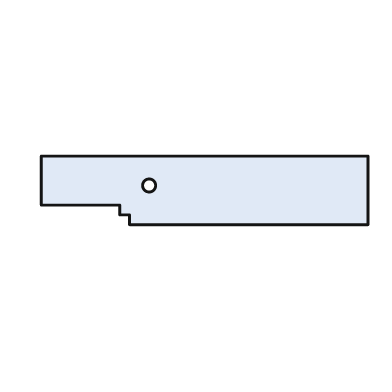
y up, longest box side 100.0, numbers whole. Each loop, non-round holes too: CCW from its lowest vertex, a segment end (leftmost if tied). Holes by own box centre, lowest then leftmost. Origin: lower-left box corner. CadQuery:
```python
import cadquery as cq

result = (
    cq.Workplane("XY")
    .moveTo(27.0, 0.0)
    .lineTo(100.0, 0.0)
    .lineTo(100.0, 21.0)
    .lineTo(0.0, 21.0)
    .lineTo(0.0, 6.0)
    .lineTo(24.0, 6.0)
    .lineTo(24.0, 3.0)
    .lineTo(27.0, 3.0)
    .close()
    .moveTo(33.0, 12.0)
    .circle(2.0)
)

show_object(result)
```